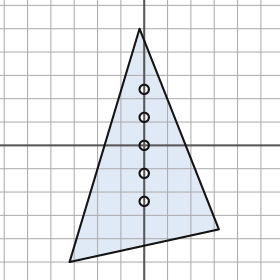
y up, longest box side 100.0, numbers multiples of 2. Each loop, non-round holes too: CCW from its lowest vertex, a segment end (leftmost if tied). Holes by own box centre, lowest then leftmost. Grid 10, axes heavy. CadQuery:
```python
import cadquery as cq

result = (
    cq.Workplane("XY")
    .moveTo(-32.0, -50.0)
    .lineTo(32.0, -36.0)
    .lineTo(-2.0, 50.0)
    .close()
    .moveTo(0.0, -24.0)
    .circle(2.0)
    .moveTo(0.0, -12.0)
    .circle(2.0)
    .moveTo(0.0, 0.0)
    .circle(2.0)
    .moveTo(0.0, 12.0)
    .circle(2.0)
    .moveTo(0.0, 24.0)
    .circle(2.0)
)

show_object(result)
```